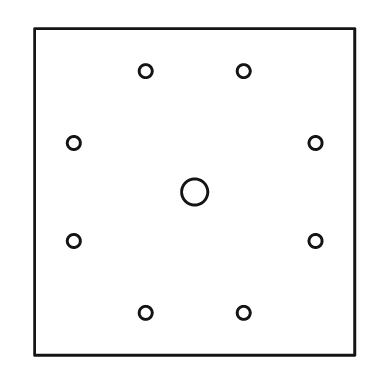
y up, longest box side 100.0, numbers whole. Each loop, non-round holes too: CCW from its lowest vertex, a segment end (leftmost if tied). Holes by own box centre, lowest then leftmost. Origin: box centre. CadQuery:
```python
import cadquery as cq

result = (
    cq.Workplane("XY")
    .moveTo(-49.0, -50.0)
    .lineTo(49.0, -50.0)
    .lineTo(49.0, 50.0)
    .lineTo(-49.0, 50.0)
    .close()
    .moveTo(-15.0, -37.0)
    .circle(2.0)
    .moveTo(15.0, -37.0)
    .circle(2.0)
    .moveTo(-37.0, -15.0)
    .circle(2.0)
    .moveTo(37.0, -15.0)
    .circle(2.0)
    .moveTo(0.0, 0.0)
    .circle(4.0)
    .moveTo(-37.0, 15.0)
    .circle(2.0)
    .moveTo(37.0, 15.0)
    .circle(2.0)
    .moveTo(-15.0, 37.0)
    .circle(2.0)
    .moveTo(15.0, 37.0)
    .circle(2.0)
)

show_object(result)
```